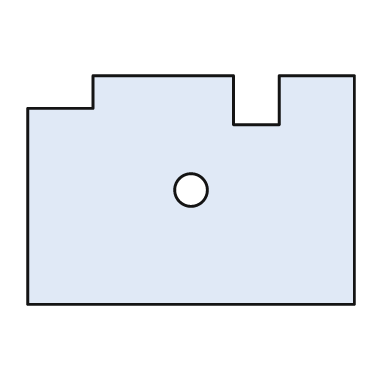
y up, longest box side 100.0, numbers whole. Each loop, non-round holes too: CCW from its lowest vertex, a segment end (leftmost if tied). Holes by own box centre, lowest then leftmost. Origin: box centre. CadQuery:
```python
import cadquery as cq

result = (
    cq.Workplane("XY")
    .moveTo(-50.0, -35.0)
    .lineTo(50.0, -35.0)
    .lineTo(50.0, 35.0)
    .lineTo(27.0, 35.0)
    .lineTo(27.0, 20.0)
    .lineTo(13.0, 20.0)
    .lineTo(13.0, 35.0)
    .lineTo(-30.0, 35.0)
    .lineTo(-30.0, 25.0)
    .lineTo(-50.0, 25.0)
    .close()
    .moveTo(0.0, 0.0)
    .circle(5.0)
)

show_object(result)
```